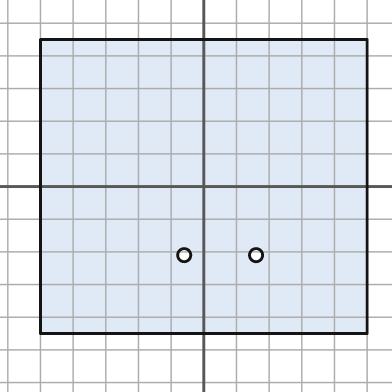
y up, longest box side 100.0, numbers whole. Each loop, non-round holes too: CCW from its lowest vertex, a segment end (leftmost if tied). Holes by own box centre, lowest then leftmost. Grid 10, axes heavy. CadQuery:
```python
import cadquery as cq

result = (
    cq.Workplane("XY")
    .moveTo(-50.0, -45.0)
    .lineTo(50.0, -45.0)
    .lineTo(50.0, 45.0)
    .lineTo(-50.0, 45.0)
    .close()
    .moveTo(-6.0, -21.0)
    .circle(2.0)
    .moveTo(16.0, -21.0)
    .circle(2.0)
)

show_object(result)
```